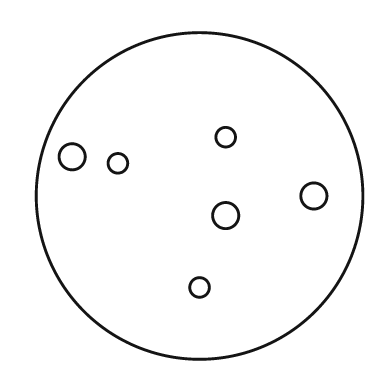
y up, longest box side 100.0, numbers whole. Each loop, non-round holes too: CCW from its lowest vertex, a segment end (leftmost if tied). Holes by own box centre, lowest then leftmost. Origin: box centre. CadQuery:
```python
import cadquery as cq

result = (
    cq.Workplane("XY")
    .moveTo(0.0, 0.0)
    .circle(50.0)
    .moveTo(0.0, -28.0)
    .circle(3.0)
    .moveTo(8.0, -6.0)
    .circle(4.0)
    .moveTo(35.0, 0.0)
    .circle(4.0)
    .moveTo(-25.0, 10.0)
    .circle(3.0)
    .moveTo(-39.0, 12.0)
    .circle(4.0)
    .moveTo(8.0, 18.0)
    .circle(3.0)
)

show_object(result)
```